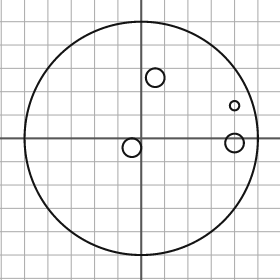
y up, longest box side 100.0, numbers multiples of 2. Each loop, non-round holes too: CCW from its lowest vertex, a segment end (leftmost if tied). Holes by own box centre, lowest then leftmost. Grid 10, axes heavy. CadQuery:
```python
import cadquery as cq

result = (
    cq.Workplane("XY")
    .moveTo(0.0, 0.0)
    .circle(50.0)
    .moveTo(-4.0, -4.0)
    .circle(4.0)
    .moveTo(40.0, -2.0)
    .circle(4.0)
    .moveTo(40.0, 14.0)
    .circle(2.0)
    .moveTo(6.0, 26.0)
    .circle(4.0)
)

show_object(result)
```